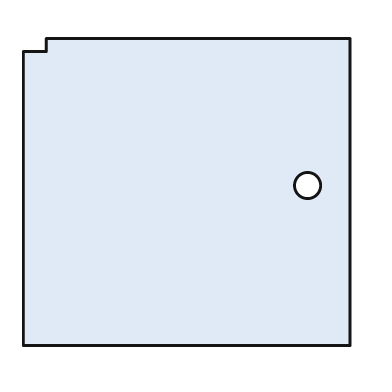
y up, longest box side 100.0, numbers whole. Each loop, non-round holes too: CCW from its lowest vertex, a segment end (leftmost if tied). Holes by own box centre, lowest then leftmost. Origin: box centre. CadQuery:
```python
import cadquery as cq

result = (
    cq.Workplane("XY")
    .moveTo(-50.0, -47.0)
    .lineTo(50.0, -47.0)
    .lineTo(50.0, 47.0)
    .lineTo(-43.0, 47.0)
    .lineTo(-43.0, 43.0)
    .lineTo(-50.0, 43.0)
    .close()
    .moveTo(37.0, 2.0)
    .circle(4.0)
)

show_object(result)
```